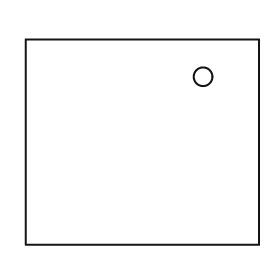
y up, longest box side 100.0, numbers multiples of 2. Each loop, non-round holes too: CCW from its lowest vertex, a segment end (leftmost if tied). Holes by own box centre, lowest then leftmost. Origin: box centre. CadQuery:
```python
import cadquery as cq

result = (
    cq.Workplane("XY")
    .moveTo(-50.0, -44.0)
    .lineTo(50.0, -44.0)
    .lineTo(50.0, 44.0)
    .lineTo(-50.0, 44.0)
    .close()
    .moveTo(26.0, 28.0)
    .circle(4.0)
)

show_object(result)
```